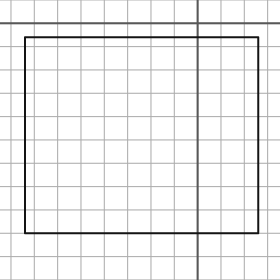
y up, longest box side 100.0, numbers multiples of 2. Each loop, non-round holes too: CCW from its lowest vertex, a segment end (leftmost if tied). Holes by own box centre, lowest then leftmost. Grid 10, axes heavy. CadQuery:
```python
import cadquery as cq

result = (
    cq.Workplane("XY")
    .moveTo(-74.0, -90.0)
    .lineTo(26.0, -90.0)
    .lineTo(26.0, -6.0)
    .lineTo(-74.0, -6.0)
    .close()
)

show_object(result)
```